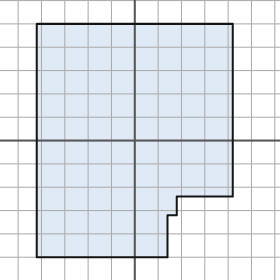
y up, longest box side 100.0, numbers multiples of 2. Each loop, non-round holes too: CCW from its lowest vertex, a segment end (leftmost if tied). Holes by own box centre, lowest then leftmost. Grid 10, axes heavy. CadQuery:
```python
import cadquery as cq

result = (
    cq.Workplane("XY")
    .moveTo(-42.0, -50.0)
    .lineTo(14.0, -50.0)
    .lineTo(14.0, -32.0)
    .lineTo(18.0, -32.0)
    .lineTo(18.0, -24.0)
    .lineTo(42.0, -24.0)
    .lineTo(42.0, 50.0)
    .lineTo(-42.0, 50.0)
    .close()
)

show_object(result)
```